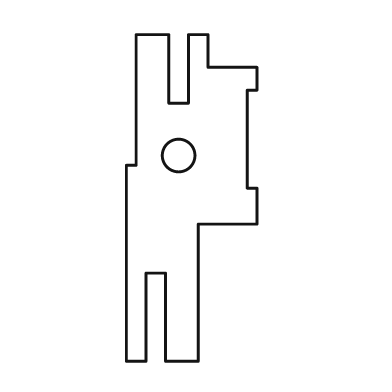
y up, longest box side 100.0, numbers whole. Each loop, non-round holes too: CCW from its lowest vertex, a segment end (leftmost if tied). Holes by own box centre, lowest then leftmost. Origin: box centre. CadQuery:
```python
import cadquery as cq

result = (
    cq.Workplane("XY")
    .moveTo(-20.0, -50.0)
    .lineTo(-14.0, -50.0)
    .lineTo(-14.0, -23.0)
    .lineTo(-8.0, -23.0)
    .lineTo(-8.0, -50.0)
    .lineTo(2.0, -50.0)
    .lineTo(2.0, -8.0)
    .lineTo(20.0, -8.0)
    .lineTo(20.0, 3.0)
    .lineTo(17.0, 3.0)
    .lineTo(17.0, 33.0)
    .lineTo(20.0, 33.0)
    .lineTo(20.0, 40.0)
    .lineTo(5.0, 40.0)
    .lineTo(5.0, 50.0)
    .lineTo(-1.0, 50.0)
    .lineTo(-1.0, 29.0)
    .lineTo(-7.0, 29.0)
    .lineTo(-7.0, 50.0)
    .lineTo(-17.0, 50.0)
    .lineTo(-17.0, 10.0)
    .lineTo(-20.0, 10.0)
    .close()
    .moveTo(-4.0, 13.0)
    .circle(5.0)
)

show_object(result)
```